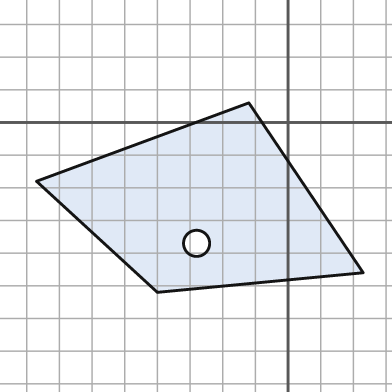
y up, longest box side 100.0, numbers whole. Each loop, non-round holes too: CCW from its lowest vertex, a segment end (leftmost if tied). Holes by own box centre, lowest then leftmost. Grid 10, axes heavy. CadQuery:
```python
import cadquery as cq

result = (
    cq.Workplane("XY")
    .moveTo(-40.0, -52.0)
    .lineTo(23.0, -46.0)
    .lineTo(-12.0, 6.0)
    .lineTo(-77.0, -18.0)
    .close()
    .moveTo(-28.0, -37.0)
    .circle(4.0)
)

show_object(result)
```